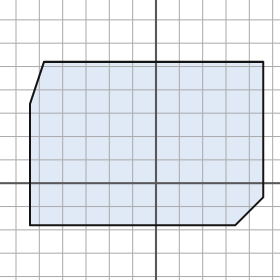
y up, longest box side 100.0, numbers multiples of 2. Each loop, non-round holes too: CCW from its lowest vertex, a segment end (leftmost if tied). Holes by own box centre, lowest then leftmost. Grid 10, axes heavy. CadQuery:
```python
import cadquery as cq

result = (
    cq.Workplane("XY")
    .moveTo(-54.0, -18.0)
    .lineTo(34.0, -18.0)
    .lineTo(46.0, -6.0)
    .lineTo(46.0, 52.0)
    .lineTo(-48.0, 52.0)
    .lineTo(-54.0, 34.0)
    .close()
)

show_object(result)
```